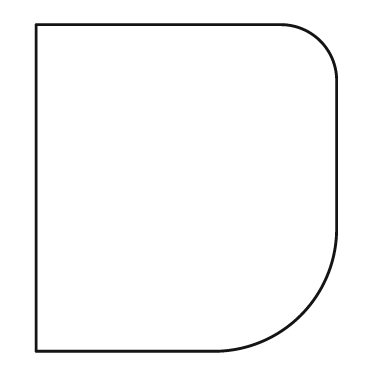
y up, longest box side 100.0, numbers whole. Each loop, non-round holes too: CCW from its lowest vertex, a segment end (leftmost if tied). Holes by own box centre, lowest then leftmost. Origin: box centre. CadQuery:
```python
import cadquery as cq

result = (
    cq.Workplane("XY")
    .moveTo(-46.0, -50.0)
    .lineTo(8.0, -50.0)
    .threePointArc((35.0, -39.0), (46.0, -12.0))
    .lineTo(46.0, 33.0)
    .threePointArc((41.0, 45.0), (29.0, 50.0))
    .lineTo(-46.0, 50.0)
    .close()
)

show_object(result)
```